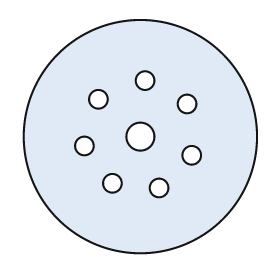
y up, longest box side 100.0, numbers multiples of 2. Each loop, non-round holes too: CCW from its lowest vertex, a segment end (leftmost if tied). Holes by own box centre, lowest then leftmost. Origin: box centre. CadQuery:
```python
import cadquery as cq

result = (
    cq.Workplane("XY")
    .moveTo(0.0, 0.0)
    .circle(50.0)
    .moveTo(8.0, -22.0)
    .circle(4.0)
    .moveTo(-12.0, -20.0)
    .circle(4.0)
    .moveTo(22.0, -8.0)
    .circle(4.0)
    .moveTo(-24.0, -4.0)
    .circle(4.0)
    .moveTo(0.0, 0.0)
    .circle(6.0)
    .moveTo(20.0, 14.0)
    .circle(4.0)
    .moveTo(-18.0, 16.0)
    .circle(4.0)
    .moveTo(2.0, 24.0)
    .circle(4.0)
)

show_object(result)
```